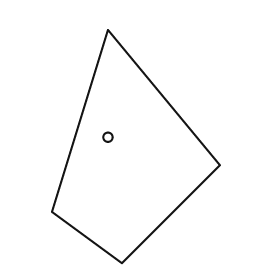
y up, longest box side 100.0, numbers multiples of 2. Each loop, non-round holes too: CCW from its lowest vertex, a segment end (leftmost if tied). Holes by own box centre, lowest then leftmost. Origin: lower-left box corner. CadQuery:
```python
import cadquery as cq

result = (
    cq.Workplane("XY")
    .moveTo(30.0, 0.0)
    .lineTo(72.0, 42.0)
    .lineTo(24.0, 100.0)
    .lineTo(0.0, 22.0)
    .close()
    .moveTo(24.0, 54.0)
    .circle(2.0)
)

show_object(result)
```